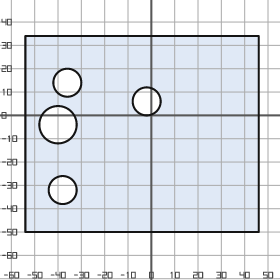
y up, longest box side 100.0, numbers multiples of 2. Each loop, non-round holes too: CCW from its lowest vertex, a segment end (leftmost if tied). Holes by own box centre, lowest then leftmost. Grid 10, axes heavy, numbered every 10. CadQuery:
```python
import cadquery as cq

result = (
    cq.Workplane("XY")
    .moveTo(-54.0, -50.0)
    .lineTo(46.0, -50.0)
    .lineTo(46.0, 34.0)
    .lineTo(-54.0, 34.0)
    .close()
    .moveTo(-38.0, -32.0)
    .circle(6.0)
    .moveTo(-40.0, -4.0)
    .circle(8.0)
    .moveTo(-2.0, 6.0)
    .circle(6.0)
    .moveTo(-36.0, 14.0)
    .circle(6.0)
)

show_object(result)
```